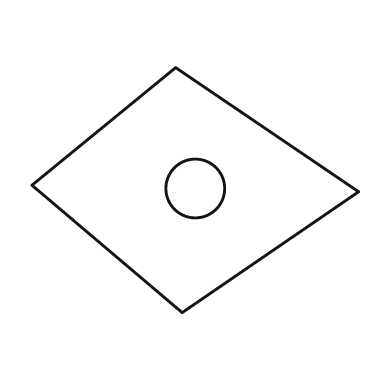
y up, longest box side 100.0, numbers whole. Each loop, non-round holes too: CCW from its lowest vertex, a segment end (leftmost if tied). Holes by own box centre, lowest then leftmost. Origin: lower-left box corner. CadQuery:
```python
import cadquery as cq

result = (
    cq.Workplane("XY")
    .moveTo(46.0, 0.0)
    .lineTo(100.0, 37.0)
    .lineTo(44.0, 75.0)
    .lineTo(0.0, 39.0)
    .close()
    .moveTo(50.0, 38.0)
    .circle(9.0)
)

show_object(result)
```